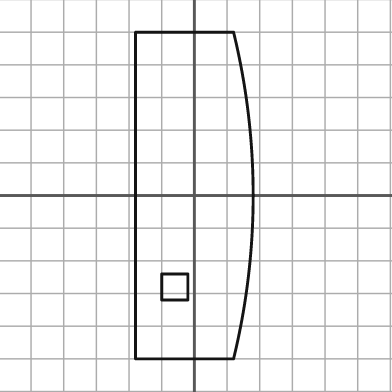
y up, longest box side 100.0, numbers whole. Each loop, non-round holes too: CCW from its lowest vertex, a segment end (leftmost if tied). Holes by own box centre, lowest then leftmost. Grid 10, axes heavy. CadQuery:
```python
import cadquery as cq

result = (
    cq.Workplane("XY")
    .moveTo(-18.0, -50.0)
    .lineTo(12.0, -50.0)
    .threePointArc((18.0, 0.0), (12.0, 50.0))
    .lineTo(-18.0, 50.0)
    .close()
    .moveTo(-10.0, -32.0)
    .lineTo(-2.0, -32.0)
    .lineTo(-2.0, -24.0)
    .lineTo(-10.0, -24.0)
    .close()
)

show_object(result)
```